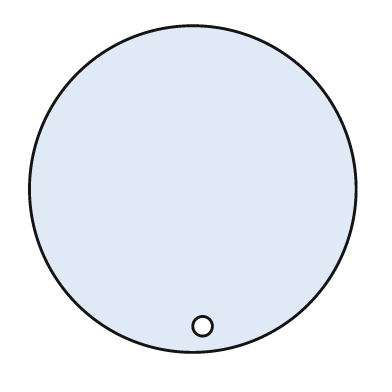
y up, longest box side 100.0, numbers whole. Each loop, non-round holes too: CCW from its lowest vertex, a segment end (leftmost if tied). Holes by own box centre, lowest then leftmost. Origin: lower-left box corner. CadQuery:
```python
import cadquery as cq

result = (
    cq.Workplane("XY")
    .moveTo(50.0, 50.0)
    .circle(50.0)
    .moveTo(53.0, 8.0)
    .circle(3.0)
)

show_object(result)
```